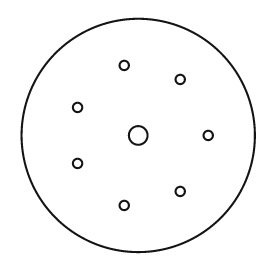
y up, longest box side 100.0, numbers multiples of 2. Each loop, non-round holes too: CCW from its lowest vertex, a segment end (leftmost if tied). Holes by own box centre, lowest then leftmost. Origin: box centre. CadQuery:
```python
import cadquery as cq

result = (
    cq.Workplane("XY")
    .moveTo(0.0, 0.0)
    .circle(50.0)
    .moveTo(-6.0, -30.0)
    .circle(2.0)
    .moveTo(18.0, -24.0)
    .circle(2.0)
    .moveTo(-26.0, -12.0)
    .circle(2.0)
    .moveTo(0.0, 0.0)
    .circle(4.0)
    .moveTo(30.0, 0.0)
    .circle(2.0)
    .moveTo(-26.0, 12.0)
    .circle(2.0)
    .moveTo(18.0, 24.0)
    .circle(2.0)
    .moveTo(-6.0, 30.0)
    .circle(2.0)
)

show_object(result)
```